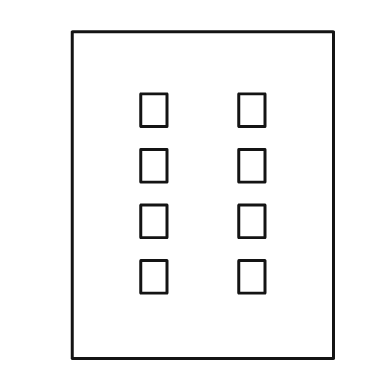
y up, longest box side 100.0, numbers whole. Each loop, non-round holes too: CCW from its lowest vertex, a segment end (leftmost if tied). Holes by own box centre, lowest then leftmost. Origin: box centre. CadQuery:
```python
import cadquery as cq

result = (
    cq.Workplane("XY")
    .moveTo(-40.0, -50.0)
    .lineTo(40.0, -50.0)
    .lineTo(40.0, 50.0)
    .lineTo(-40.0, 50.0)
    .close()
    .moveTo(-19.0, -30.0)
    .lineTo(-11.0, -30.0)
    .lineTo(-11.0, -20.0)
    .lineTo(-19.0, -20.0)
    .close()
    .moveTo(11.0, -30.0)
    .lineTo(19.0, -30.0)
    .lineTo(19.0, -20.0)
    .lineTo(11.0, -20.0)
    .close()
    .moveTo(-19.0, -13.0)
    .lineTo(-11.0, -13.0)
    .lineTo(-11.0, -3.0)
    .lineTo(-19.0, -3.0)
    .close()
    .moveTo(11.0, -13.0)
    .lineTo(19.0, -13.0)
    .lineTo(19.0, -3.0)
    .lineTo(11.0, -3.0)
    .close()
    .moveTo(-19.0, 4.0)
    .lineTo(-11.0, 4.0)
    .lineTo(-11.0, 14.0)
    .lineTo(-19.0, 14.0)
    .close()
    .moveTo(11.0, 4.0)
    .lineTo(19.0, 4.0)
    .lineTo(19.0, 14.0)
    .lineTo(11.0, 14.0)
    .close()
    .moveTo(-19.0, 21.0)
    .lineTo(-11.0, 21.0)
    .lineTo(-11.0, 31.0)
    .lineTo(-19.0, 31.0)
    .close()
    .moveTo(11.0, 21.0)
    .lineTo(19.0, 21.0)
    .lineTo(19.0, 31.0)
    .lineTo(11.0, 31.0)
    .close()
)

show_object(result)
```